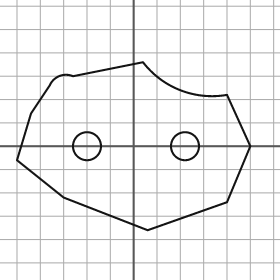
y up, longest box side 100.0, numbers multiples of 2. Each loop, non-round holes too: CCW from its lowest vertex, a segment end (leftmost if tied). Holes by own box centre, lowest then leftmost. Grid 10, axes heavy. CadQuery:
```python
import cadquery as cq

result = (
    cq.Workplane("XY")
    .moveTo(6.0, -36.0)
    .lineTo(40.0, -24.0)
    .lineTo(50.0, 0.0)
    .lineTo(40.0, 22.0)
    .threePointArc((20.0, 24.0), (4.0, 36.0))
    .lineTo(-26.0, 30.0)
    .threePointArc((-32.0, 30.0), (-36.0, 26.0))
    .lineTo(-44.0, 14.0)
    .lineTo(-50.0, -6.0)
    .lineTo(-30.0, -22.0)
    .close()
    .moveTo(-20.0, 0.0)
    .circle(6.0)
    .moveTo(22.0, 0.0)
    .circle(6.0)
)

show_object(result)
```